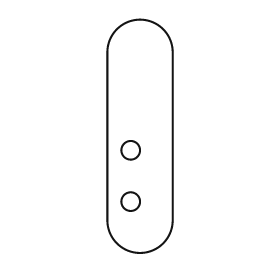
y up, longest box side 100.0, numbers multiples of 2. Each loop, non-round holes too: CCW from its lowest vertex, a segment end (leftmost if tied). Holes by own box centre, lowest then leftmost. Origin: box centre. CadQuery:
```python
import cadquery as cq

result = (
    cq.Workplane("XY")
    .moveTo(-14.0, -36.0)
    .threePointArc((0.0, -50.0), (14.0, -36.0))
    .lineTo(14.0, 36.0)
    .threePointArc((0.0, 50.0), (-14.0, 36.0))
    .close()
    .moveTo(-4.0, -28.0)
    .circle(4.0)
    .moveTo(-4.0, -6.0)
    .circle(4.0)
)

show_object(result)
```